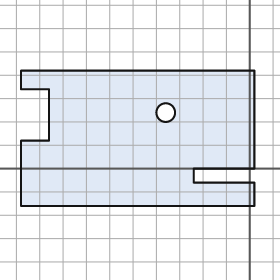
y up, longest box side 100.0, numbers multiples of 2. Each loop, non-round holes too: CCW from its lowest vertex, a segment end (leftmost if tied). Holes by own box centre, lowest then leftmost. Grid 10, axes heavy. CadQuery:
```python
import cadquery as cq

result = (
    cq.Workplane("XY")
    .moveTo(-98.0, -16.0)
    .lineTo(2.0, -16.0)
    .lineTo(2.0, -6.0)
    .lineTo(-24.0, -6.0)
    .lineTo(-24.0, 0.0)
    .lineTo(2.0, 0.0)
    .lineTo(2.0, 42.0)
    .lineTo(-98.0, 42.0)
    .lineTo(-98.0, 34.0)
    .lineTo(-86.0, 34.0)
    .lineTo(-86.0, 12.0)
    .lineTo(-98.0, 12.0)
    .close()
    .moveTo(-36.0, 24.0)
    .circle(4.0)
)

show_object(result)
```